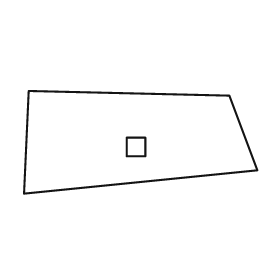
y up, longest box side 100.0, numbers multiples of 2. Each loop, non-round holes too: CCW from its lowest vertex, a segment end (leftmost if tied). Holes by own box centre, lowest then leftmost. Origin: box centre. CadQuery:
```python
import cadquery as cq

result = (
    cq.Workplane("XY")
    .moveTo(-50.0, -22.0)
    .lineTo(50.0, -12.0)
    .lineTo(38.0, 20.0)
    .lineTo(-48.0, 22.0)
    .close()
    .moveTo(-6.0, -6.0)
    .lineTo(2.0, -6.0)
    .lineTo(2.0, 2.0)
    .lineTo(-6.0, 2.0)
    .close()
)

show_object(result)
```